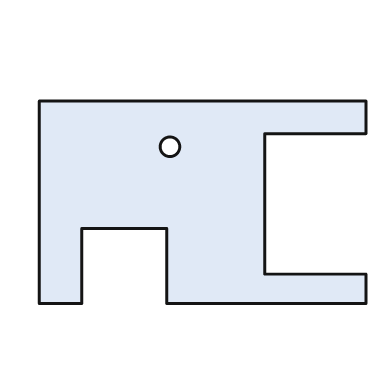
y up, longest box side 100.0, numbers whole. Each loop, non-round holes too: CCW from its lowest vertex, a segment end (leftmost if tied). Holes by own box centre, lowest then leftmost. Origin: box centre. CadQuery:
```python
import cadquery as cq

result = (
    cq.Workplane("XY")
    .moveTo(-50.0, -31.0)
    .lineTo(-37.0, -31.0)
    .lineTo(-37.0, -8.0)
    .lineTo(-11.0, -8.0)
    .lineTo(-11.0, -31.0)
    .lineTo(50.0, -31.0)
    .lineTo(50.0, -22.0)
    .lineTo(19.0, -22.0)
    .lineTo(19.0, 21.0)
    .lineTo(50.0, 21.0)
    .lineTo(50.0, 31.0)
    .lineTo(-50.0, 31.0)
    .close()
    .moveTo(-10.0, 17.0)
    .circle(3.0)
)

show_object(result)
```